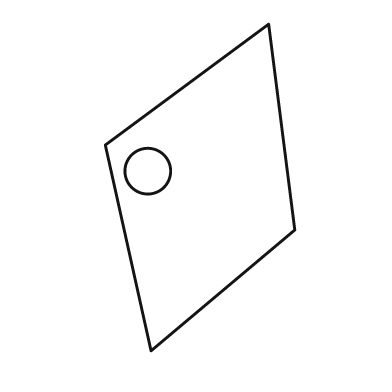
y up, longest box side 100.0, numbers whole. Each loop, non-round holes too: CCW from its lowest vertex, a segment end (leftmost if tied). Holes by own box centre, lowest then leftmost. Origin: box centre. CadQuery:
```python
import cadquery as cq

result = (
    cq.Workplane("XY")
    .moveTo(-15.0, -50.0)
    .lineTo(29.0, -13.0)
    .lineTo(21.0, 50.0)
    .lineTo(-29.0, 13.0)
    .close()
    .moveTo(-16.0, 5.0)
    .circle(7.0)
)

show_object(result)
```